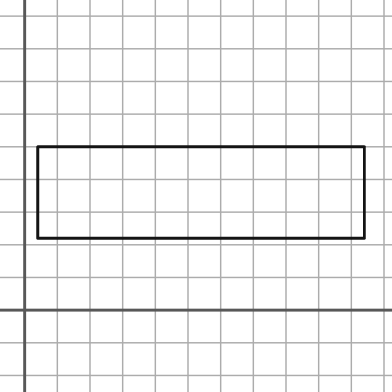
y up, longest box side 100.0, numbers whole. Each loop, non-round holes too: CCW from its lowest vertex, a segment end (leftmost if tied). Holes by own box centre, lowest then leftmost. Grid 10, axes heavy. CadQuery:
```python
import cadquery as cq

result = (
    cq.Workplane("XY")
    .moveTo(4.0, 22.0)
    .lineTo(104.0, 22.0)
    .lineTo(104.0, 50.0)
    .lineTo(4.0, 50.0)
    .close()
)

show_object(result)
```